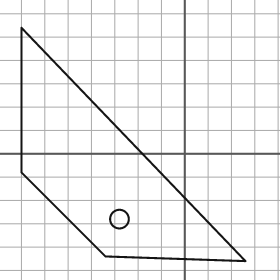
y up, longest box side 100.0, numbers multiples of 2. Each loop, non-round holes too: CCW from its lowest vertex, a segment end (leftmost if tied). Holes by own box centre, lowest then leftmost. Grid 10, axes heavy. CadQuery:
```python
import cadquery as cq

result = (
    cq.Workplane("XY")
    .moveTo(26.0, -46.0)
    .lineTo(-70.0, 54.0)
    .lineTo(-70.0, -8.0)
    .lineTo(-34.0, -44.0)
    .close()
    .moveTo(-28.0, -28.0)
    .circle(4.0)
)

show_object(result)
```